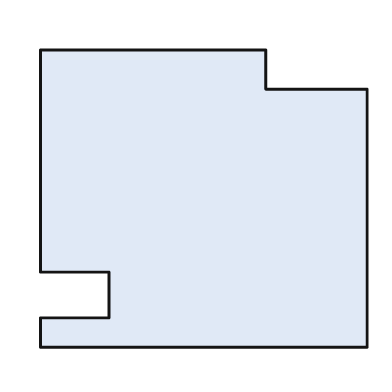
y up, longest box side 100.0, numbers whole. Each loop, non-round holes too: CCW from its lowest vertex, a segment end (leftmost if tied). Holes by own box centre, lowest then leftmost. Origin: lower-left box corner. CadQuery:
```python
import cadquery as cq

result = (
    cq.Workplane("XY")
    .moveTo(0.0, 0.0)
    .lineTo(100.0, 0.0)
    .lineTo(100.0, 79.0)
    .lineTo(69.0, 79.0)
    .lineTo(69.0, 91.0)
    .lineTo(0.0, 91.0)
    .lineTo(0.0, 23.0)
    .lineTo(21.0, 23.0)
    .lineTo(21.0, 9.0)
    .lineTo(0.0, 9.0)
    .close()
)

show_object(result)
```